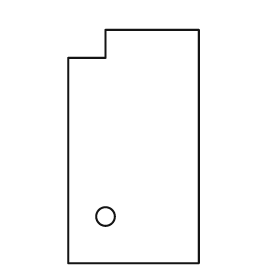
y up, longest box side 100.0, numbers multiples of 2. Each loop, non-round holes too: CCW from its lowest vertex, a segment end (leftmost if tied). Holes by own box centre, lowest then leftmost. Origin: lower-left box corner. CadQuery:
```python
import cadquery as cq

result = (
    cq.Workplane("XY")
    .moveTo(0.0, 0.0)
    .lineTo(56.0, 0.0)
    .lineTo(56.0, 100.0)
    .lineTo(16.0, 100.0)
    .lineTo(16.0, 88.0)
    .lineTo(0.0, 88.0)
    .close()
    .moveTo(16.0, 20.0)
    .circle(4.0)
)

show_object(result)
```